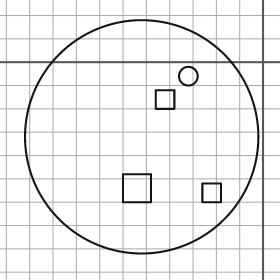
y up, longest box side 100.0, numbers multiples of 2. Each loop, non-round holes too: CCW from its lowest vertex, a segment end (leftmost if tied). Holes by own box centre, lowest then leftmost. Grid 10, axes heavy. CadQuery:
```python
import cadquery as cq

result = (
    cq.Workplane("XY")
    .moveTo(-52.0, -32.0)
    .circle(50.0)
    .moveTo(-26.0, -60.0)
    .lineTo(-18.0, -60.0)
    .lineTo(-18.0, -52.0)
    .lineTo(-26.0, -52.0)
    .close()
    .moveTo(-60.0, -60.0)
    .lineTo(-48.0, -60.0)
    .lineTo(-48.0, -48.0)
    .lineTo(-60.0, -48.0)
    .close()
    .moveTo(-46.0, -20.0)
    .lineTo(-38.0, -20.0)
    .lineTo(-38.0, -12.0)
    .lineTo(-46.0, -12.0)
    .close()
    .moveTo(-32.0, -6.0)
    .circle(4.0)
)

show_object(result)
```